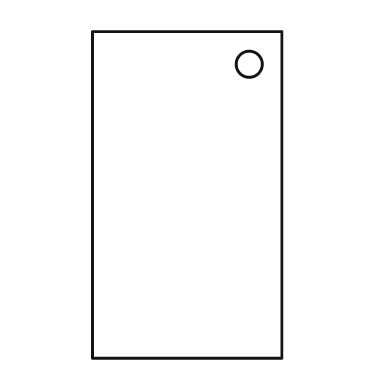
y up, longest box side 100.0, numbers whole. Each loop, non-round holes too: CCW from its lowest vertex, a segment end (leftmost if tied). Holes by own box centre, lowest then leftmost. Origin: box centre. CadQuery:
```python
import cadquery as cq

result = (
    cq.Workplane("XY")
    .moveTo(-29.0, -50.0)
    .lineTo(29.0, -50.0)
    .lineTo(29.0, 50.0)
    .lineTo(-29.0, 50.0)
    .close()
    .moveTo(19.0, 40.0)
    .circle(4.0)
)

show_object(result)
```